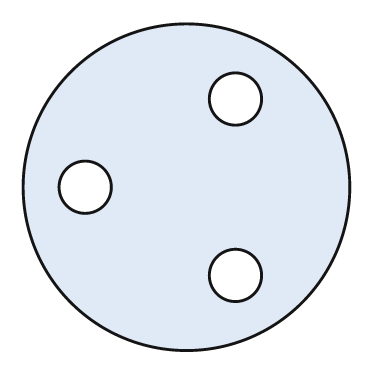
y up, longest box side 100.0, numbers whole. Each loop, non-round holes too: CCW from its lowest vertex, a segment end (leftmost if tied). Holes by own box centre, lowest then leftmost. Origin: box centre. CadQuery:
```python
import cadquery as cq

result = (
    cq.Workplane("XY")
    .moveTo(0.0, 0.0)
    .circle(50.0)
    .moveTo(15.0, -27.0)
    .circle(8.0)
    .moveTo(-31.0, 0.0)
    .circle(8.0)
    .moveTo(15.0, 27.0)
    .circle(8.0)
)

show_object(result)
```